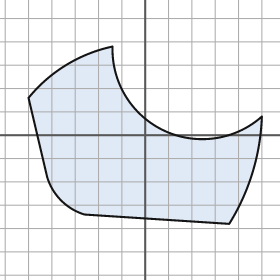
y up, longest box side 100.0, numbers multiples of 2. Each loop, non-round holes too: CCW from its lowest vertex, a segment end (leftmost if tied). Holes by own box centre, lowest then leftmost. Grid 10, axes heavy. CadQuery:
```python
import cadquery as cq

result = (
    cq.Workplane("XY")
    .moveTo(36.0, -38.0)
    .threePointArc((46.0, -16.0), (50.0, 8.0))
    .threePointArc((8.0, 2.0), (-14.0, 38.0))
    .threePointArc((-34.0, 30.0), (-50.0, 16.0))
    .lineTo(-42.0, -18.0)
    .threePointArc((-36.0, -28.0), (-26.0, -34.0))
    .close()
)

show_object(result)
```